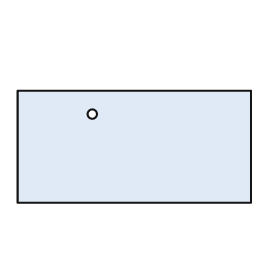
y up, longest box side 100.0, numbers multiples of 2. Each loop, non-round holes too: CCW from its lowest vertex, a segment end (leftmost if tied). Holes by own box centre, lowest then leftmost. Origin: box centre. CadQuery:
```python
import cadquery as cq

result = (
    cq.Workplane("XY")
    .moveTo(-50.0, -24.0)
    .lineTo(50.0, -24.0)
    .lineTo(50.0, 24.0)
    .lineTo(-50.0, 24.0)
    .close()
    .moveTo(-18.0, 14.0)
    .circle(2.0)
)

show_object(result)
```